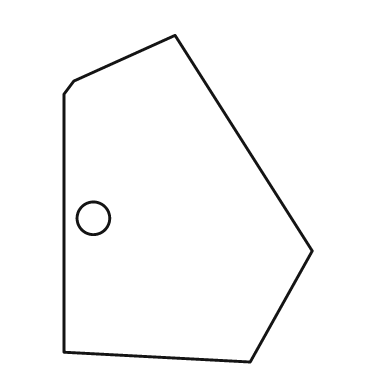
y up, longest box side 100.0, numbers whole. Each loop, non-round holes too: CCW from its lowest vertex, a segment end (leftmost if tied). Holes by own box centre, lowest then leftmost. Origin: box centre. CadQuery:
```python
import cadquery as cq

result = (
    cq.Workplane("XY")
    .moveTo(19.0, -50.0)
    .lineTo(38.0, -16.0)
    .lineTo(-4.0, 50.0)
    .lineTo(-35.0, 36.0)
    .lineTo(-38.0, 32.0)
    .lineTo(-38.0, -47.0)
    .close()
    .moveTo(-29.0, -6.0)
    .circle(5.0)
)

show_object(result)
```